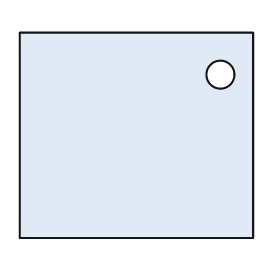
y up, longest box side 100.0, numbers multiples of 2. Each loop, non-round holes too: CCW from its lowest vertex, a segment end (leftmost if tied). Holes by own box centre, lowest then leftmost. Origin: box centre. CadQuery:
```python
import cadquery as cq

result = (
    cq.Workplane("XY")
    .moveTo(-50.0, -44.0)
    .lineTo(50.0, -44.0)
    .lineTo(50.0, 44.0)
    .lineTo(-50.0, 44.0)
    .close()
    .moveTo(36.0, 26.0)
    .circle(6.0)
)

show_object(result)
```